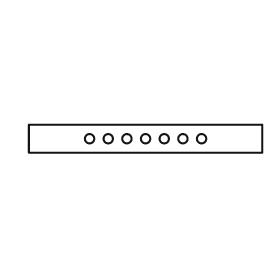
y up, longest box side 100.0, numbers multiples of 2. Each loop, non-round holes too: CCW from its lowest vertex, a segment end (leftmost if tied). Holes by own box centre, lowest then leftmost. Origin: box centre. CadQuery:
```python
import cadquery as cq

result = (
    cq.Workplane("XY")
    .moveTo(-50.0, -6.0)
    .lineTo(50.0, -6.0)
    .lineTo(50.0, 6.0)
    .lineTo(-50.0, 6.0)
    .close()
    .moveTo(-24.0, 0.0)
    .circle(2.0)
    .moveTo(-16.0, 0.0)
    .circle(2.0)
    .moveTo(-8.0, 0.0)
    .circle(2.0)
    .moveTo(0.0, 0.0)
    .circle(2.0)
    .moveTo(8.0, 0.0)
    .circle(2.0)
    .moveTo(16.0, 0.0)
    .circle(2.0)
    .moveTo(24.0, 0.0)
    .circle(2.0)
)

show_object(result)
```